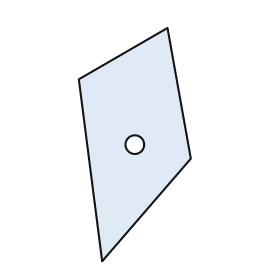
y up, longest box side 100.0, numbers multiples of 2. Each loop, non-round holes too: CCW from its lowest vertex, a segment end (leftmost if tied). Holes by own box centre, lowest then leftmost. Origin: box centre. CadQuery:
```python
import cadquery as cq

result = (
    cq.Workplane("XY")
    .moveTo(-14.0, -50.0)
    .lineTo(24.0, -6.0)
    .lineTo(14.0, 50.0)
    .lineTo(-24.0, 28.0)
    .close()
    .moveTo(0.0, 0.0)
    .circle(4.0)
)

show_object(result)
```